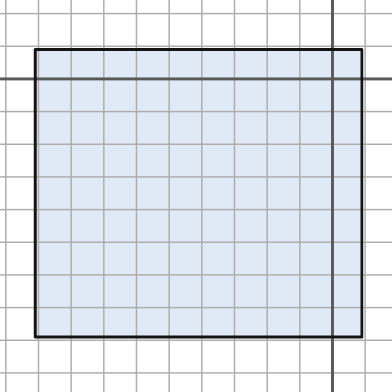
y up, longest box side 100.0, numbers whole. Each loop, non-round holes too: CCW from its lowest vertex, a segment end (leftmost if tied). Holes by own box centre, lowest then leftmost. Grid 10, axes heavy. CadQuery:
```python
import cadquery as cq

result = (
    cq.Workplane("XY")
    .moveTo(-91.0, -79.0)
    .lineTo(9.0, -79.0)
    .lineTo(9.0, 9.0)
    .lineTo(-91.0, 9.0)
    .close()
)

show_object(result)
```